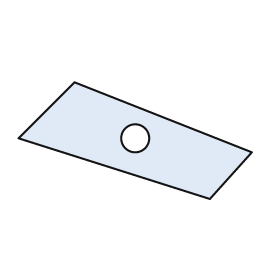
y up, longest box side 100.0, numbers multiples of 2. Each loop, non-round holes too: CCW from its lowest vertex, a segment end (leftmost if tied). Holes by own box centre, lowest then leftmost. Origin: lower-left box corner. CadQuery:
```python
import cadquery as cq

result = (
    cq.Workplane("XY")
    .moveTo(82.0, 0.0)
    .lineTo(100.0, 20.0)
    .lineTo(24.0, 50.0)
    .lineTo(0.0, 26.0)
    .close()
    .moveTo(50.0, 26.0)
    .circle(6.0)
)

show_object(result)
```